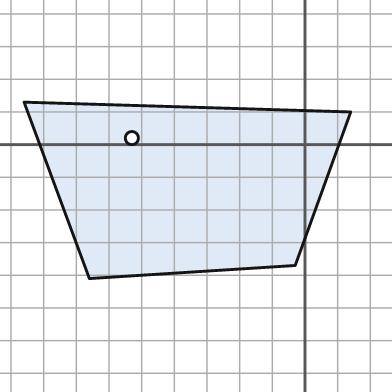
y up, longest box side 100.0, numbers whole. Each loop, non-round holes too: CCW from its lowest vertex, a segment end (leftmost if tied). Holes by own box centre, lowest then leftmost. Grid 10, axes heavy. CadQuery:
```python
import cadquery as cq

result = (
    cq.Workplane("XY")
    .moveTo(-66.0, -41.0)
    .lineTo(-3.0, -37.0)
    .lineTo(14.0, 10.0)
    .lineTo(-86.0, 13.0)
    .close()
    .moveTo(-53.0, 2.0)
    .circle(2.0)
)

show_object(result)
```